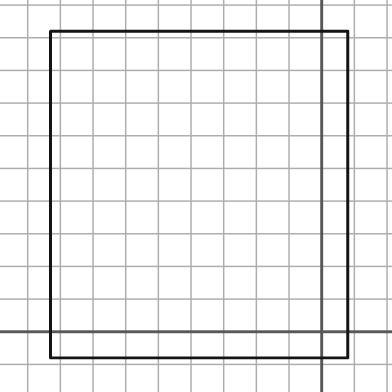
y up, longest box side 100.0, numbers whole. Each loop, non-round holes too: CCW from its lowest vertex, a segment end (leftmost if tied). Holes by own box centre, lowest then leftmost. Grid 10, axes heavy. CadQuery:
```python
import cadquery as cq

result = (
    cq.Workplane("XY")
    .moveTo(-83.0, -8.0)
    .lineTo(8.0, -8.0)
    .lineTo(8.0, 92.0)
    .lineTo(-83.0, 92.0)
    .close()
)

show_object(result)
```